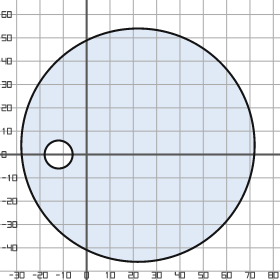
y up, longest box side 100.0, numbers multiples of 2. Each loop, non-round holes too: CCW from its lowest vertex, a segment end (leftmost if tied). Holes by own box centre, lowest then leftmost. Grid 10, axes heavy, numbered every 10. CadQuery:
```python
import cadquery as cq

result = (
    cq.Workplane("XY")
    .moveTo(22.0, 4.0)
    .circle(50.0)
    .moveTo(-12.0, 0.0)
    .circle(6.0)
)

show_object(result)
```